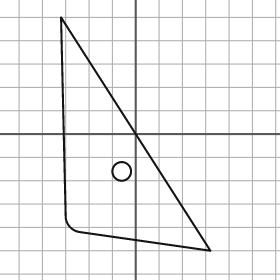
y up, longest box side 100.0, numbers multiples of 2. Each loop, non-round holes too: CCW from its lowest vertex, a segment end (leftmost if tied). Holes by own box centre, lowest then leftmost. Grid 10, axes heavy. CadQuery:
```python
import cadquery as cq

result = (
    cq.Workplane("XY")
    .moveTo(32.0, -50.0)
    .lineTo(-32.0, 50.0)
    .lineTo(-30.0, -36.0)
    .threePointArc((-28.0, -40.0), (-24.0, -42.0))
    .close()
    .moveTo(-6.0, -16.0)
    .circle(4.0)
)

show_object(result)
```